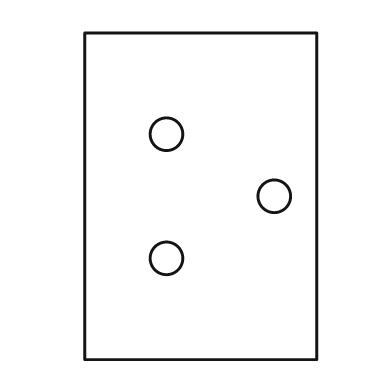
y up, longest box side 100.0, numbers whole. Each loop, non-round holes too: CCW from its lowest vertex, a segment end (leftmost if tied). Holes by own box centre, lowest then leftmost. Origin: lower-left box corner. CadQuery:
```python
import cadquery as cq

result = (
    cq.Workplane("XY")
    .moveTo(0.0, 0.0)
    .lineTo(71.0, 0.0)
    .lineTo(71.0, 100.0)
    .lineTo(0.0, 100.0)
    .close()
    .moveTo(25.0, 31.0)
    .circle(5.0)
    .moveTo(58.0, 50.0)
    .circle(5.0)
    .moveTo(25.0, 69.0)
    .circle(5.0)
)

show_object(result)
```